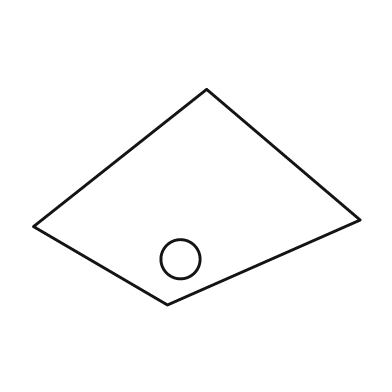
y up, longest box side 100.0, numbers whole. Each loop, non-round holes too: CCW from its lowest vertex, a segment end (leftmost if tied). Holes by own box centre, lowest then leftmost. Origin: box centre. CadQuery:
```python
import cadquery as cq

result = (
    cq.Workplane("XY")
    .moveTo(-9.0, -33.0)
    .lineTo(50.0, -7.0)
    .lineTo(3.0, 33.0)
    .lineTo(-50.0, -9.0)
    .close()
    .moveTo(-5.0, -19.0)
    .circle(6.0)
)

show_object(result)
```